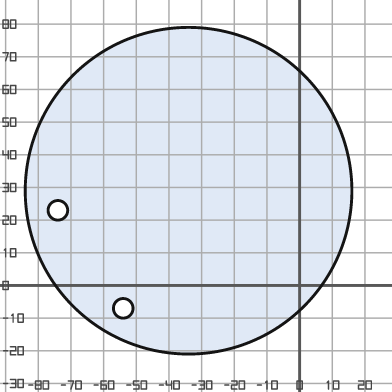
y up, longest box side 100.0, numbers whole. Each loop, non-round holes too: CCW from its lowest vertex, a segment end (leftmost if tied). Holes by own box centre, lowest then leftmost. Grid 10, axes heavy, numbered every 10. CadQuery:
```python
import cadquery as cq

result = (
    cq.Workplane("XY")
    .moveTo(-34.0, 29.0)
    .circle(50.0)
    .moveTo(-54.0, -7.0)
    .circle(3.0)
    .moveTo(-74.0, 23.0)
    .circle(3.0)
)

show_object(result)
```